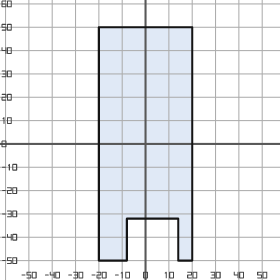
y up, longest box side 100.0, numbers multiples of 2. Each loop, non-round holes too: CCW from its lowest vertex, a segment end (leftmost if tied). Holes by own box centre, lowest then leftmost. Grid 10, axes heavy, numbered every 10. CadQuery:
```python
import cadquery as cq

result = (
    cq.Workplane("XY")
    .moveTo(-20.0, -50.0)
    .lineTo(-8.0, -50.0)
    .lineTo(-8.0, -32.0)
    .lineTo(14.0, -32.0)
    .lineTo(14.0, -50.0)
    .lineTo(20.0, -50.0)
    .lineTo(20.0, 50.0)
    .lineTo(-20.0, 50.0)
    .close()
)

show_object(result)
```